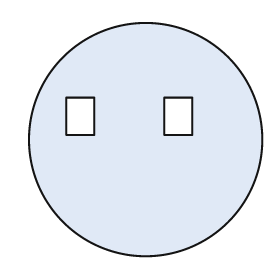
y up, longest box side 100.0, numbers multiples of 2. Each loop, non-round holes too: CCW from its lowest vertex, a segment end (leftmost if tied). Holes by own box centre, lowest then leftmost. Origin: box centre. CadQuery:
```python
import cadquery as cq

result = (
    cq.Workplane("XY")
    .moveTo(0.0, 0.0)
    .circle(50.0)
    .moveTo(-34.0, 2.0)
    .lineTo(-22.0, 2.0)
    .lineTo(-22.0, 18.0)
    .lineTo(-34.0, 18.0)
    .close()
    .moveTo(8.0, 2.0)
    .lineTo(20.0, 2.0)
    .lineTo(20.0, 18.0)
    .lineTo(8.0, 18.0)
    .close()
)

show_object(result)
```